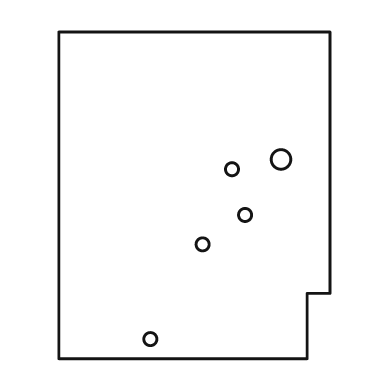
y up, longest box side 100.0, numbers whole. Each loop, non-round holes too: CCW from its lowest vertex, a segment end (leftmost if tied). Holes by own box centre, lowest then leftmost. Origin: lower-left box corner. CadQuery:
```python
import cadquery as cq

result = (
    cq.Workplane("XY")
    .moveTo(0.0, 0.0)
    .lineTo(76.0, 0.0)
    .lineTo(76.0, 20.0)
    .lineTo(83.0, 20.0)
    .lineTo(83.0, 100.0)
    .lineTo(0.0, 100.0)
    .close()
    .moveTo(28.0, 6.0)
    .circle(2.0)
    .moveTo(44.0, 35.0)
    .circle(2.0)
    .moveTo(57.0, 44.0)
    .circle(2.0)
    .moveTo(53.0, 58.0)
    .circle(2.0)
    .moveTo(68.0, 61.0)
    .circle(3.0)
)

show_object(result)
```